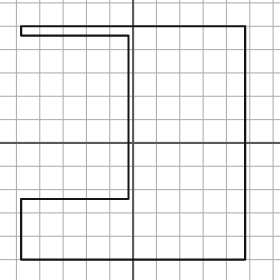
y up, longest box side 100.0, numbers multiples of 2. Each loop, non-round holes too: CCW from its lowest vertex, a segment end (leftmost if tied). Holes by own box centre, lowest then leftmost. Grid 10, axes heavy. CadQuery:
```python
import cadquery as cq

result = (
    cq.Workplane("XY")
    .moveTo(-48.0, -50.0)
    .lineTo(48.0, -50.0)
    .lineTo(48.0, 50.0)
    .lineTo(-48.0, 50.0)
    .lineTo(-48.0, 46.0)
    .lineTo(-2.0, 46.0)
    .lineTo(-2.0, -24.0)
    .lineTo(-48.0, -24.0)
    .close()
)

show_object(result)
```